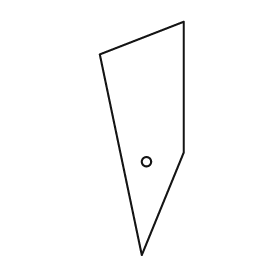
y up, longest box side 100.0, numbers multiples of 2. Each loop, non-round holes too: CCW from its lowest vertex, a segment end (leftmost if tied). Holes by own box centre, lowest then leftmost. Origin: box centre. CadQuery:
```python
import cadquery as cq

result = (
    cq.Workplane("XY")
    .moveTo(0.0, -50.0)
    .lineTo(18.0, -6.0)
    .lineTo(18.0, 50.0)
    .lineTo(-18.0, 36.0)
    .close()
    .moveTo(2.0, -10.0)
    .circle(2.0)
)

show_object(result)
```